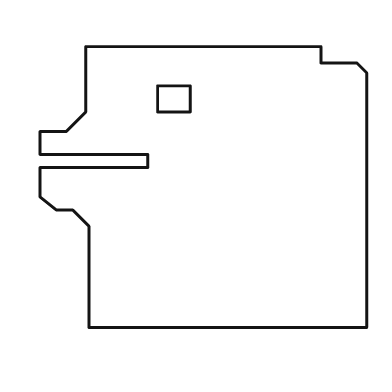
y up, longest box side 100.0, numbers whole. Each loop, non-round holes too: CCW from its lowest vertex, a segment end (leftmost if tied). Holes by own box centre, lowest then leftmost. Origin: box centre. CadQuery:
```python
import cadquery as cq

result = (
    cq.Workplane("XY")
    .moveTo(-35.0, -43.0)
    .lineTo(50.0, -43.0)
    .lineTo(50.0, 35.0)
    .lineTo(47.0, 38.0)
    .lineTo(36.0, 38.0)
    .lineTo(36.0, 43.0)
    .lineTo(-36.0, 43.0)
    .lineTo(-36.0, 23.0)
    .lineTo(-42.0, 17.0)
    .lineTo(-50.0, 17.0)
    .lineTo(-50.0, 10.0)
    .lineTo(-17.0, 10.0)
    .lineTo(-17.0, 6.0)
    .lineTo(-50.0, 6.0)
    .lineTo(-50.0, -3.0)
    .lineTo(-45.0, -7.0)
    .lineTo(-40.0, -7.0)
    .lineTo(-35.0, -12.0)
    .close()
    .moveTo(-14.0, 23.0)
    .lineTo(-4.0, 23.0)
    .lineTo(-4.0, 31.0)
    .lineTo(-14.0, 31.0)
    .close()
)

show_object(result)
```